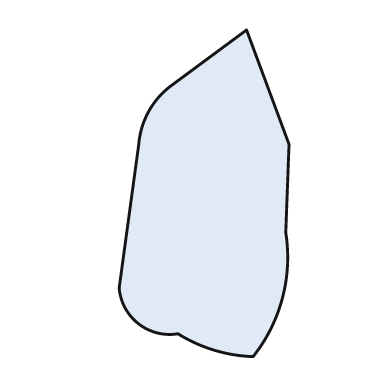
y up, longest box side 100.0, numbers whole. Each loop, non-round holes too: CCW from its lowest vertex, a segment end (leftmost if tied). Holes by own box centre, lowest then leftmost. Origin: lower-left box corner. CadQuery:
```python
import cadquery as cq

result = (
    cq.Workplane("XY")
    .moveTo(41.0, 0.0)
    .threePointArc((50.0, 18.0), (51.0, 38.0))
    .lineTo(52.0, 65.0)
    .lineTo(39.0, 100.0)
    .lineTo(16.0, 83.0)
    .threePointArc((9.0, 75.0), (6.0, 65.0))
    .lineTo(0.0, 21.0)
    .threePointArc((6.0, 10.0), (18.0, 7.0))
    .threePointArc((29.0, 2.0), (41.0, 0.0))
    .close()
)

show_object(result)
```